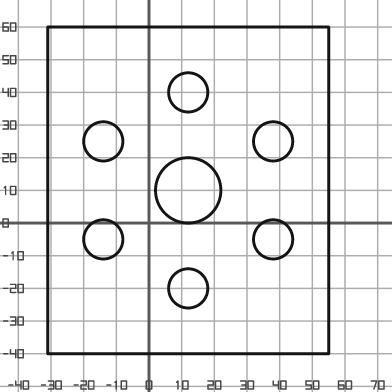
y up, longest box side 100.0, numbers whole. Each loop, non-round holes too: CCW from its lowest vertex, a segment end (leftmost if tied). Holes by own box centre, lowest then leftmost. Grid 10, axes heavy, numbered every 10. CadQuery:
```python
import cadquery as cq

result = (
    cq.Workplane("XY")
    .moveTo(-31.0, -40.0)
    .lineTo(55.0, -40.0)
    .lineTo(55.0, 60.0)
    .lineTo(-31.0, 60.0)
    .close()
    .moveTo(12.0, -20.0)
    .circle(6.0)
    .moveTo(-14.0, -5.0)
    .circle(6.0)
    .moveTo(38.0, -5.0)
    .circle(6.0)
    .moveTo(12.0, 10.0)
    .circle(10.0)
    .moveTo(-14.0, 25.0)
    .circle(6.0)
    .moveTo(38.0, 25.0)
    .circle(6.0)
    .moveTo(12.0, 40.0)
    .circle(6.0)
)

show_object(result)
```